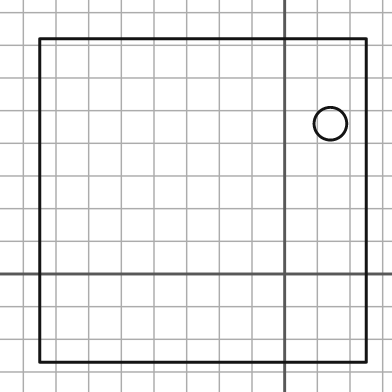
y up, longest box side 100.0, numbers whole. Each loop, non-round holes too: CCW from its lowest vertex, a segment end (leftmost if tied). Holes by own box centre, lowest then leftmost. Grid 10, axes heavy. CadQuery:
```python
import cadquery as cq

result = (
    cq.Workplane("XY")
    .moveTo(-75.0, -27.0)
    .lineTo(25.0, -27.0)
    .lineTo(25.0, 72.0)
    .lineTo(-75.0, 72.0)
    .close()
    .moveTo(14.0, 46.0)
    .circle(5.0)
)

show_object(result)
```